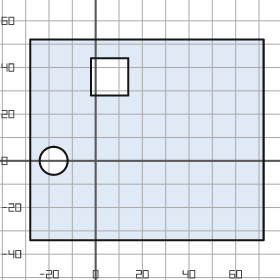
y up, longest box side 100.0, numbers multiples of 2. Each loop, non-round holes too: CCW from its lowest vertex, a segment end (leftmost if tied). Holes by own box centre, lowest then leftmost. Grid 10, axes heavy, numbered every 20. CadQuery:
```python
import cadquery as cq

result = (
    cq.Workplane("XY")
    .moveTo(-28.0, -34.0)
    .lineTo(72.0, -34.0)
    .lineTo(72.0, 52.0)
    .lineTo(-28.0, 52.0)
    .close()
    .moveTo(-18.0, 0.0)
    .circle(6.0)
    .moveTo(-2.0, 28.0)
    .lineTo(14.0, 28.0)
    .lineTo(14.0, 44.0)
    .lineTo(-2.0, 44.0)
    .close()
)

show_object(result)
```